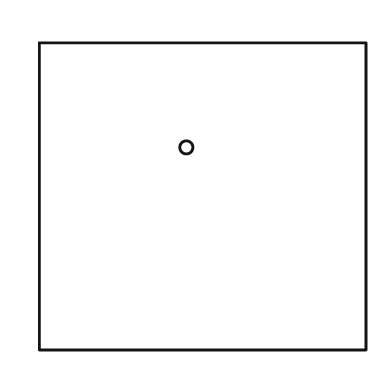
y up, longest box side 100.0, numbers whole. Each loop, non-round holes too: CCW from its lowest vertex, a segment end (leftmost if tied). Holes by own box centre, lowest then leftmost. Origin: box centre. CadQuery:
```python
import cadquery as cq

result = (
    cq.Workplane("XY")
    .moveTo(-50.0, -47.0)
    .lineTo(50.0, -47.0)
    .lineTo(50.0, 47.0)
    .lineTo(-50.0, 47.0)
    .close()
    .moveTo(-5.0, 15.0)
    .circle(2.0)
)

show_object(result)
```